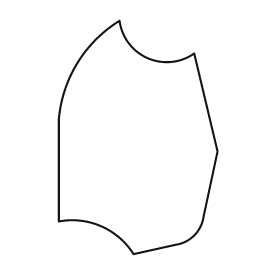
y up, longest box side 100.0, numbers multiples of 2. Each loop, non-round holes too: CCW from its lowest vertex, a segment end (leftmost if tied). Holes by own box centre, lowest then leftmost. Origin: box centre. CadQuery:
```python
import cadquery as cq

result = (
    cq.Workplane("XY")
    .moveTo(-2.0, -50.0)
    .lineTo(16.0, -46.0)
    .threePointArc((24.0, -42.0), (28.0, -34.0))
    .lineTo(34.0, -6.0)
    .lineTo(24.0, 36.0)
    .threePointArc((4.0, 34.0), (-8.0, 50.0))
    .threePointArc((-26.0, 32.0), (-34.0, 8.0))
    .lineTo(-34.0, -36.0)
    .threePointArc((-16.0, -38.0), (-2.0, -50.0))
    .close()
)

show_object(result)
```